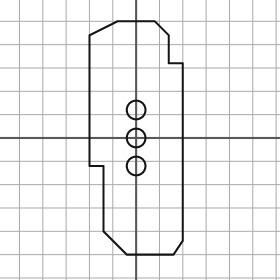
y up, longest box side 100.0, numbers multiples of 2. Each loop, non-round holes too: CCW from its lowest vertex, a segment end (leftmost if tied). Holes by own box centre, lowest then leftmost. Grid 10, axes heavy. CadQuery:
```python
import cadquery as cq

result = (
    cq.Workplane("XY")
    .moveTo(-4.0, -50.0)
    .lineTo(16.0, -50.0)
    .lineTo(20.0, -44.0)
    .lineTo(20.0, 32.0)
    .lineTo(14.0, 32.0)
    .lineTo(14.0, 44.0)
    .lineTo(8.0, 50.0)
    .lineTo(-8.0, 50.0)
    .lineTo(-20.0, 44.0)
    .lineTo(-20.0, -12.0)
    .lineTo(-14.0, -12.0)
    .lineTo(-14.0, -40.0)
    .close()
    .moveTo(0.0, -12.0)
    .circle(4.0)
    .moveTo(0.0, 0.0)
    .circle(4.0)
    .moveTo(0.0, 12.0)
    .circle(4.0)
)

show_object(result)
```